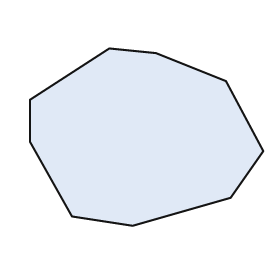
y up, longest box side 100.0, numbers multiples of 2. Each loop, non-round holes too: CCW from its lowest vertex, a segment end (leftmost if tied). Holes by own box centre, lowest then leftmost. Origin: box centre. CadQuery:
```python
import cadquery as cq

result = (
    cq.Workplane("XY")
    .moveTo(-6.0, -38.0)
    .lineTo(36.0, -26.0)
    .lineTo(50.0, -6.0)
    .lineTo(34.0, 24.0)
    .lineTo(4.0, 36.0)
    .lineTo(-16.0, 38.0)
    .lineTo(-50.0, 16.0)
    .lineTo(-50.0, -2.0)
    .lineTo(-32.0, -34.0)
    .close()
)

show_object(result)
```